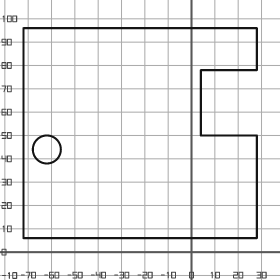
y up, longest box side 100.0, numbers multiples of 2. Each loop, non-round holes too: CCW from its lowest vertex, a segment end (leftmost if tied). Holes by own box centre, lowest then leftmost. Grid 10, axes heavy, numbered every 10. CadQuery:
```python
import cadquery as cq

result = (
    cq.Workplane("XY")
    .moveTo(-72.0, 6.0)
    .lineTo(28.0, 6.0)
    .lineTo(28.0, 50.0)
    .lineTo(4.0, 50.0)
    .lineTo(4.0, 78.0)
    .lineTo(28.0, 78.0)
    .lineTo(28.0, 96.0)
    .lineTo(-72.0, 96.0)
    .close()
    .moveTo(-62.0, 44.0)
    .circle(6.0)
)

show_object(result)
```